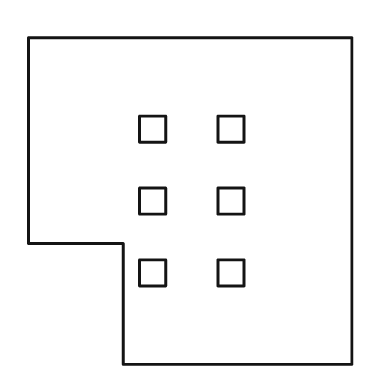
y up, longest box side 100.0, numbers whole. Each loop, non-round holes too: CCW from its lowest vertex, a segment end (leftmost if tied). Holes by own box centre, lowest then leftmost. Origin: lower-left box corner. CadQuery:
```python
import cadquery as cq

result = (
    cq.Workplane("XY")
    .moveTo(29.0, 0.0)
    .lineTo(99.0, 0.0)
    .lineTo(99.0, 100.0)
    .lineTo(0.0, 100.0)
    .lineTo(0.0, 37.0)
    .lineTo(29.0, 37.0)
    .close()
    .moveTo(34.0, 24.0)
    .lineTo(42.0, 24.0)
    .lineTo(42.0, 32.0)
    .lineTo(34.0, 32.0)
    .close()
    .moveTo(58.0, 24.0)
    .lineTo(66.0, 24.0)
    .lineTo(66.0, 32.0)
    .lineTo(58.0, 32.0)
    .close()
    .moveTo(34.0, 46.0)
    .lineTo(42.0, 46.0)
    .lineTo(42.0, 54.0)
    .lineTo(34.0, 54.0)
    .close()
    .moveTo(58.0, 46.0)
    .lineTo(66.0, 46.0)
    .lineTo(66.0, 54.0)
    .lineTo(58.0, 54.0)
    .close()
    .moveTo(34.0, 68.0)
    .lineTo(42.0, 68.0)
    .lineTo(42.0, 76.0)
    .lineTo(34.0, 76.0)
    .close()
    .moveTo(58.0, 68.0)
    .lineTo(66.0, 68.0)
    .lineTo(66.0, 76.0)
    .lineTo(58.0, 76.0)
    .close()
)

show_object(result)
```